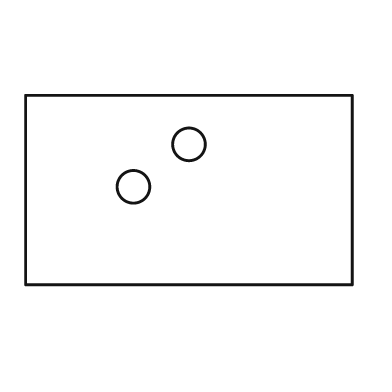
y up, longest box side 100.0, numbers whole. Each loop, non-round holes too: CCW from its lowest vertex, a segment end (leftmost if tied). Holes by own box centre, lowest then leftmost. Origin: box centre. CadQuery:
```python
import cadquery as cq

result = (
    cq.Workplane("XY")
    .moveTo(-50.0, -29.0)
    .lineTo(50.0, -29.0)
    .lineTo(50.0, 29.0)
    .lineTo(-50.0, 29.0)
    .close()
    .moveTo(-17.0, 1.0)
    .circle(5.0)
    .moveTo(0.0, 14.0)
    .circle(5.0)
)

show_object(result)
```